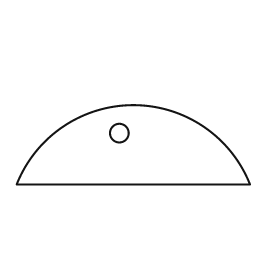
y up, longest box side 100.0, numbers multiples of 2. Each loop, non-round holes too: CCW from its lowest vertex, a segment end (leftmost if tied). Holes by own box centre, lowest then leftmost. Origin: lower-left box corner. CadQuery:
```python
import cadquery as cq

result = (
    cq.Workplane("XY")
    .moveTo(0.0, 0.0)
    .lineTo(100.0, 0.0)
    .threePointArc((50.0, 34.0), (0.0, 0.0))
    .close()
    .moveTo(44.0, 22.0)
    .circle(4.0)
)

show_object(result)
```